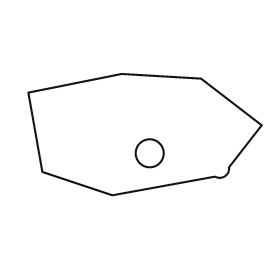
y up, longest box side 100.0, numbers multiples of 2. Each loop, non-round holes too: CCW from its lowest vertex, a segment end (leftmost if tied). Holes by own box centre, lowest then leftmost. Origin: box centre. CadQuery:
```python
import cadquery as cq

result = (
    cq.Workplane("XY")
    .moveTo(-14.0, -26.0)
    .lineTo(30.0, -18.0)
    .threePointArc((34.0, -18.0), (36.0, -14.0))
    .lineTo(50.0, 4.0)
    .lineTo(24.0, 24.0)
    .lineTo(-10.0, 26.0)
    .lineTo(-50.0, 18.0)
    .lineTo(-44.0, -16.0)
    .close()
    .moveTo(2.0, -8.0)
    .circle(6.0)
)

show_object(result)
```